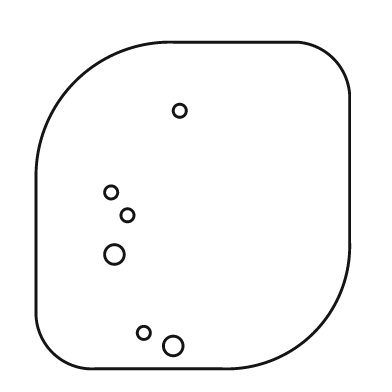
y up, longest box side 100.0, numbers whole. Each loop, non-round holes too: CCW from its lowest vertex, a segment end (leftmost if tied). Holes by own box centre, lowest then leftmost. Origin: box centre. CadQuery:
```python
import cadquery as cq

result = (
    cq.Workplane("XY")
    .moveTo(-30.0, -50.0)
    .lineTo(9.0, -50.0)
    .threePointArc((37.0, -39.0), (48.0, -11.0))
    .lineTo(48.0, 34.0)
    .threePointArc((43.0, 45.0), (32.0, 50.0))
    .lineTo(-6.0, 50.0)
    .threePointArc((-36.0, 38.0), (-48.0, 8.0))
    .lineTo(-48.0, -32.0)
    .threePointArc((-43.0, -45.0), (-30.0, -50.0))
    .close()
    .moveTo(-6.0, -43.0)
    .circle(3.0)
    .moveTo(-15.0, -39.0)
    .circle(2.0)
    .moveTo(-24.0, -15.0)
    .circle(3.0)
    .moveTo(-20.0, -3.0)
    .circle(2.0)
    .moveTo(-25.0, 4.0)
    .circle(2.0)
    .moveTo(-4.0, 29.0)
    .circle(2.0)
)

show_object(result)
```